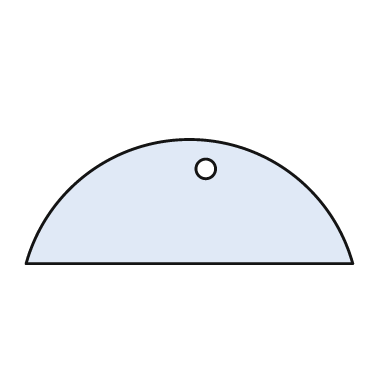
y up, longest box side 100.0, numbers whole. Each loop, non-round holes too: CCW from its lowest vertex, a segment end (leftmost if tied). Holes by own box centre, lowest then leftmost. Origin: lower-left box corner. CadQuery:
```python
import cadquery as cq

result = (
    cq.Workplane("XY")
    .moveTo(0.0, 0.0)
    .lineTo(100.0, 0.0)
    .threePointArc((50.0, 38.0), (0.0, 0.0))
    .close()
    .moveTo(55.0, 29.0)
    .circle(3.0)
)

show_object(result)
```